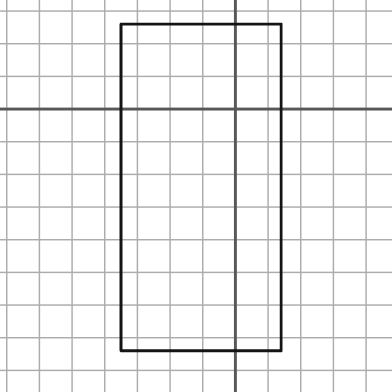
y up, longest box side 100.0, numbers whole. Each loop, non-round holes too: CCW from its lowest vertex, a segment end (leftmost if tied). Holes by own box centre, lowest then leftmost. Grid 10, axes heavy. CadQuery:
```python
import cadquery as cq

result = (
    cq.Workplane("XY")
    .moveTo(-35.0, -74.0)
    .lineTo(14.0, -74.0)
    .lineTo(14.0, 26.0)
    .lineTo(-35.0, 26.0)
    .close()
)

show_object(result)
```